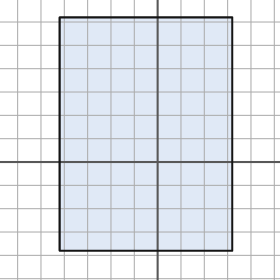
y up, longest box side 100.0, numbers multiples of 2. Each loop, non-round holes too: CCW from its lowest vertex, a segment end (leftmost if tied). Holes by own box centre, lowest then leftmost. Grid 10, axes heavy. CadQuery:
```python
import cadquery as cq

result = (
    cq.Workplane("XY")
    .moveTo(-42.0, -38.0)
    .lineTo(32.0, -38.0)
    .lineTo(32.0, 62.0)
    .lineTo(-42.0, 62.0)
    .close()
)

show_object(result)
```